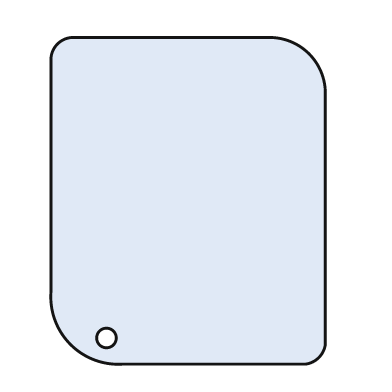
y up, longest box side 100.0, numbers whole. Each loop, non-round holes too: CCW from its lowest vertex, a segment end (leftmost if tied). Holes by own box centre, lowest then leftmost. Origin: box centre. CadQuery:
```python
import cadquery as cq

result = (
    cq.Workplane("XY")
    .moveTo(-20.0, -50.0)
    .lineTo(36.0, -50.0)
    .threePointArc((40.0, -48.0), (42.0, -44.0))
    .lineTo(42.0, 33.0)
    .threePointArc((37.0, 45.0), (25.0, 50.0))
    .lineTo(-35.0, 50.0)
    .threePointArc((-40.0, 48.0), (-42.0, 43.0))
    .lineTo(-42.0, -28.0)
    .threePointArc((-36.0, -44.0), (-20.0, -50.0))
    .close()
    .moveTo(-25.0, -42.0)
    .circle(3.0)
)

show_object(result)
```